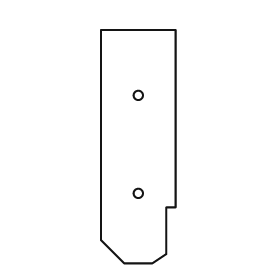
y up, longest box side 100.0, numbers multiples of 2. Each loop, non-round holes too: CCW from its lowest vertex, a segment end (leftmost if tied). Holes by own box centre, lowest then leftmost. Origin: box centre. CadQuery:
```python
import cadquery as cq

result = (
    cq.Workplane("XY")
    .moveTo(-6.0, -50.0)
    .lineTo(6.0, -50.0)
    .lineTo(12.0, -46.0)
    .lineTo(12.0, -26.0)
    .lineTo(16.0, -26.0)
    .lineTo(16.0, 50.0)
    .lineTo(-16.0, 50.0)
    .lineTo(-16.0, -40.0)
    .close()
    .moveTo(0.0, -20.0)
    .circle(2.0)
    .moveTo(0.0, 22.0)
    .circle(2.0)
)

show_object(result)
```